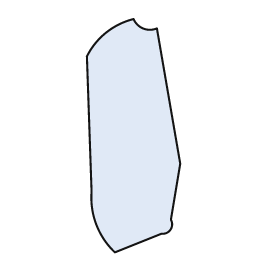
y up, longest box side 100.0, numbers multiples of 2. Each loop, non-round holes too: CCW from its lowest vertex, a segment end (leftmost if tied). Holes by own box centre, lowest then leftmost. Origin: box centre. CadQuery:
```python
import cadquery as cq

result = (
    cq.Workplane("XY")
    .moveTo(-8.0, -50.0)
    .lineTo(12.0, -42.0)
    .threePointArc((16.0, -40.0), (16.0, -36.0))
    .lineTo(20.0, -12.0)
    .lineTo(10.0, 46.0)
    .threePointArc((4.0, 46.0), (0.0, 50.0))
    .threePointArc((-12.0, 44.0), (-20.0, 34.0))
    .lineTo(-18.0, -24.0)
    .threePointArc((-16.0, -38.0), (-8.0, -50.0))
    .close()
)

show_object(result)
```